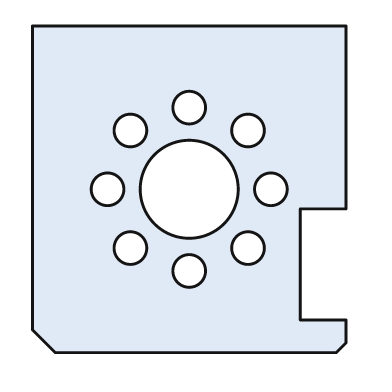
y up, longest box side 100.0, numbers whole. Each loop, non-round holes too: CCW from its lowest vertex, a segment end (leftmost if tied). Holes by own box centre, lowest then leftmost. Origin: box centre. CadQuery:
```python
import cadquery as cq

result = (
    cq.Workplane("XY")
    .moveTo(-41.0, -50.0)
    .lineTo(45.0, -50.0)
    .lineTo(48.0, -47.0)
    .lineTo(48.0, -40.0)
    .lineTo(34.0, -40.0)
    .lineTo(34.0, -6.0)
    .lineTo(48.0, -6.0)
    .lineTo(48.0, 50.0)
    .lineTo(-48.0, 50.0)
    .lineTo(-48.0, -43.0)
    .close()
    .moveTo(0.0, -25.0)
    .circle(5.0)
    .moveTo(-18.0, -18.0)
    .circle(5.0)
    .moveTo(18.0, -18.0)
    .circle(5.0)
    .moveTo(-25.0, 0.0)
    .circle(5.0)
    .moveTo(0.0, 0.0)
    .circle(15.0)
    .moveTo(25.0, 0.0)
    .circle(5.0)
    .moveTo(-18.0, 18.0)
    .circle(5.0)
    .moveTo(18.0, 18.0)
    .circle(5.0)
    .moveTo(0.0, 25.0)
    .circle(5.0)
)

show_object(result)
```